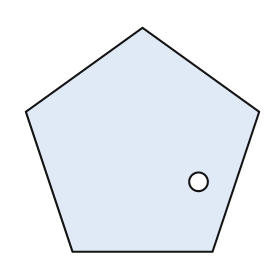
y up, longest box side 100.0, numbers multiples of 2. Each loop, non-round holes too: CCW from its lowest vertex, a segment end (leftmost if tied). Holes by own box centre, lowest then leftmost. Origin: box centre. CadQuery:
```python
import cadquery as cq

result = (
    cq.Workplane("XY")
    .moveTo(-30.0, -48.0)
    .lineTo(30.0, -48.0)
    .lineTo(50.0, 12.0)
    .lineTo(0.0, 48.0)
    .lineTo(-50.0, 12.0)
    .close()
    .moveTo(24.0, -18.0)
    .circle(4.0)
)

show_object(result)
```